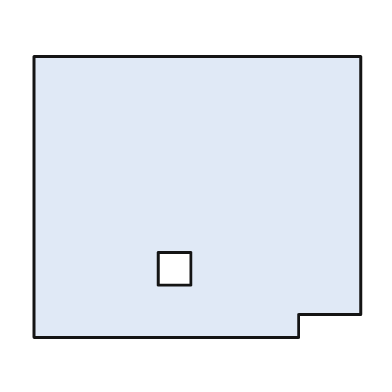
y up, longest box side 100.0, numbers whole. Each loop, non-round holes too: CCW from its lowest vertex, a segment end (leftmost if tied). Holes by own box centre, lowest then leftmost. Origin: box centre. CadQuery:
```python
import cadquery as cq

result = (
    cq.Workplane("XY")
    .moveTo(-50.0, -43.0)
    .lineTo(31.0, -43.0)
    .lineTo(31.0, -36.0)
    .lineTo(50.0, -36.0)
    .lineTo(50.0, 43.0)
    .lineTo(-50.0, 43.0)
    .close()
    .moveTo(-12.0, -27.0)
    .lineTo(-2.0, -27.0)
    .lineTo(-2.0, -17.0)
    .lineTo(-12.0, -17.0)
    .close()
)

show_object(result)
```